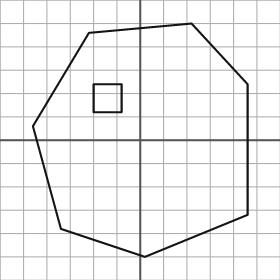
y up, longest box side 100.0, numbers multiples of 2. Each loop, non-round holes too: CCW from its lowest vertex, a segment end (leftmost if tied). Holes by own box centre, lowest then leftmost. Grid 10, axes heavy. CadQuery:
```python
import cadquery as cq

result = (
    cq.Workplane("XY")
    .moveTo(2.0, -50.0)
    .lineTo(46.0, -32.0)
    .lineTo(46.0, 24.0)
    .lineTo(22.0, 50.0)
    .lineTo(-22.0, 46.0)
    .lineTo(-46.0, 6.0)
    .lineTo(-34.0, -38.0)
    .close()
    .moveTo(-20.0, 12.0)
    .lineTo(-8.0, 12.0)
    .lineTo(-8.0, 24.0)
    .lineTo(-20.0, 24.0)
    .close()
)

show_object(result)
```